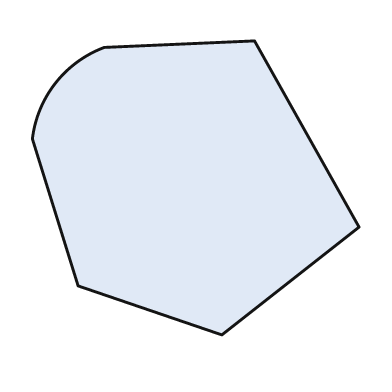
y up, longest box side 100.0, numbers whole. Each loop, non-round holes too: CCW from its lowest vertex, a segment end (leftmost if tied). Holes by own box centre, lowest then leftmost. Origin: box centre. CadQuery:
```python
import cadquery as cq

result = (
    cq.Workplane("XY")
    .moveTo(8.0, -45.0)
    .lineTo(50.0, -12.0)
    .lineTo(18.0, 45.0)
    .lineTo(-28.0, 43.0)
    .threePointArc((-43.0, 32.0), (-50.0, 15.0))
    .lineTo(-36.0, -30.0)
    .close()
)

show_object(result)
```